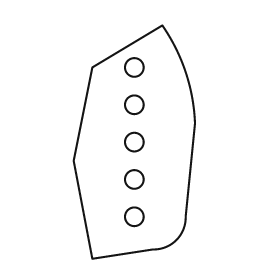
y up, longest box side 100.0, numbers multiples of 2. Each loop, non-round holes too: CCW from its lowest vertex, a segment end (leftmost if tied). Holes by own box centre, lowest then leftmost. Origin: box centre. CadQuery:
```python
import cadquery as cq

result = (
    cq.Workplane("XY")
    .moveTo(-18.0, -50.0)
    .lineTo(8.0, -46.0)
    .threePointArc((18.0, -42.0), (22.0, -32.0))
    .lineTo(26.0, 8.0)
    .threePointArc((22.0, 30.0), (12.0, 50.0))
    .lineTo(-18.0, 32.0)
    .lineTo(-26.0, -8.0)
    .close()
    .moveTo(0.0, -32.0)
    .circle(4.0)
    .moveTo(0.0, -16.0)
    .circle(4.0)
    .moveTo(0.0, 0.0)
    .circle(4.0)
    .moveTo(0.0, 16.0)
    .circle(4.0)
    .moveTo(0.0, 32.0)
    .circle(4.0)
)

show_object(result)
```